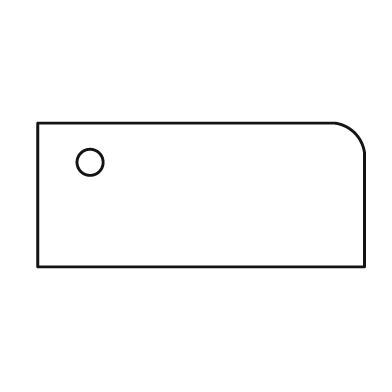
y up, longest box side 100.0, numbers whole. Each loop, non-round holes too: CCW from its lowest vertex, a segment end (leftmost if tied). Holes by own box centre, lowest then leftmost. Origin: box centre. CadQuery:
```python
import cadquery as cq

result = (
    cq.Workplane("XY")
    .moveTo(-50.0, -22.0)
    .lineTo(50.0, -22.0)
    .lineTo(50.0, 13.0)
    .threePointArc((47.0, 19.0), (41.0, 22.0))
    .lineTo(-50.0, 22.0)
    .close()
    .moveTo(-34.0, 10.0)
    .circle(4.0)
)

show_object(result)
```